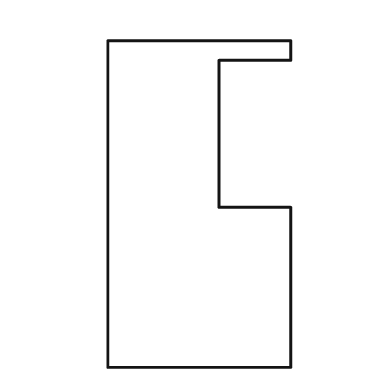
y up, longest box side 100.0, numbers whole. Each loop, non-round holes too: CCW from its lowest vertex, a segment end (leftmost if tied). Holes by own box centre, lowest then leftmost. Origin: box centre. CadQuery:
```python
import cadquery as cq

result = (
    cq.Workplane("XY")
    .moveTo(-28.0, -50.0)
    .lineTo(28.0, -50.0)
    .lineTo(28.0, -1.0)
    .lineTo(6.0, -1.0)
    .lineTo(6.0, 44.0)
    .lineTo(28.0, 44.0)
    .lineTo(28.0, 50.0)
    .lineTo(-28.0, 50.0)
    .close()
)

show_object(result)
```